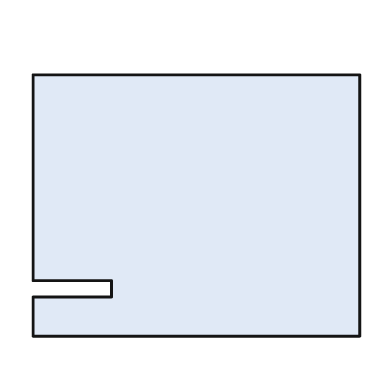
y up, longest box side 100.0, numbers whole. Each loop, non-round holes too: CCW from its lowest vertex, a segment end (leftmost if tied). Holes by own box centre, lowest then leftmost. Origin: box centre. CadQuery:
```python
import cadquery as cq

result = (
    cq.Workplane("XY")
    .moveTo(-50.0, -40.0)
    .lineTo(50.0, -40.0)
    .lineTo(50.0, 40.0)
    .lineTo(-50.0, 40.0)
    .lineTo(-50.0, -23.0)
    .lineTo(-26.0, -23.0)
    .lineTo(-26.0, -28.0)
    .lineTo(-50.0, -28.0)
    .close()
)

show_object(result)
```